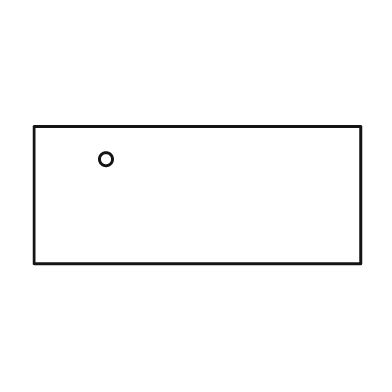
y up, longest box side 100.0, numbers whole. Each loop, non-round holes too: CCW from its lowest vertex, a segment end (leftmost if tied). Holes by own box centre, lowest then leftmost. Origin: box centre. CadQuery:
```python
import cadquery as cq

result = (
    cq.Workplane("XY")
    .moveTo(-50.0, -21.0)
    .lineTo(50.0, -21.0)
    .lineTo(50.0, 21.0)
    .lineTo(-50.0, 21.0)
    .close()
    .moveTo(-28.0, 11.0)
    .circle(2.0)
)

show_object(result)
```